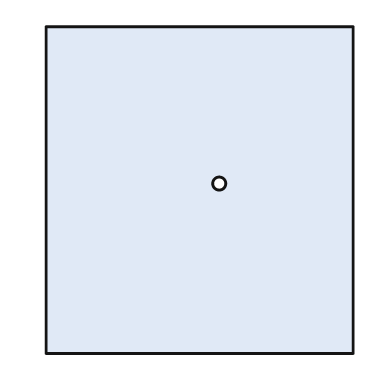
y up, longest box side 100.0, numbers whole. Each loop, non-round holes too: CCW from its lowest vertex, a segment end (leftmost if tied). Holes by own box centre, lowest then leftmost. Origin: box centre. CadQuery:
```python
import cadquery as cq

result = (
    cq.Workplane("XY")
    .moveTo(-47.0, -50.0)
    .lineTo(47.0, -50.0)
    .lineTo(47.0, 50.0)
    .lineTo(-47.0, 50.0)
    .close()
    .moveTo(6.0, 2.0)
    .circle(2.0)
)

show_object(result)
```